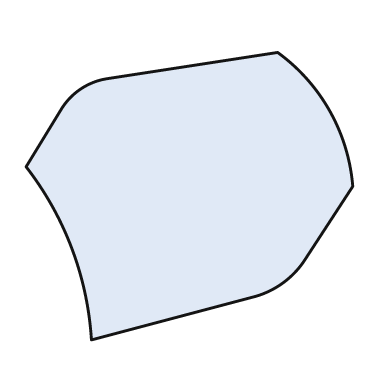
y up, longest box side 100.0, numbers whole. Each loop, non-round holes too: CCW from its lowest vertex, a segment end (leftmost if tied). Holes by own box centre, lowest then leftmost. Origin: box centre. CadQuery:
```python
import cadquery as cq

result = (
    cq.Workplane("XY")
    .moveTo(-30.0, -44.0)
    .lineTo(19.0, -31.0)
    .threePointArc((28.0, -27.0), (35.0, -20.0))
    .lineTo(50.0, 3.0)
    .threePointArc((43.0, 26.0), (27.0, 44.0))
    .lineTo(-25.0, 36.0)
    .threePointArc((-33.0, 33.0), (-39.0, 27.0))
    .lineTo(-50.0, 9.0)
    .threePointArc((-36.0, -16.0), (-30.0, -44.0))
    .close()
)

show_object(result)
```